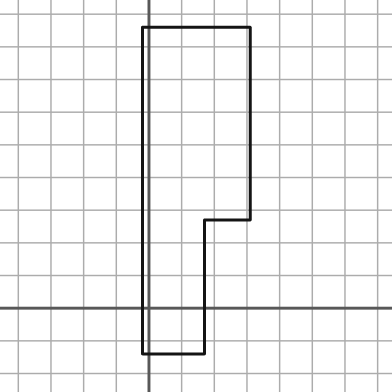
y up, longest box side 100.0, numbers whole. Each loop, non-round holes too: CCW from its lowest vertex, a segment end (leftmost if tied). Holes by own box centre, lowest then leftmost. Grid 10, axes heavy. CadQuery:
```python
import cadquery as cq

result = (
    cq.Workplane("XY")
    .moveTo(-2.0, -14.0)
    .lineTo(17.0, -14.0)
    .lineTo(17.0, 27.0)
    .lineTo(31.0, 27.0)
    .lineTo(31.0, 86.0)
    .lineTo(-2.0, 86.0)
    .close()
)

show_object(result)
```